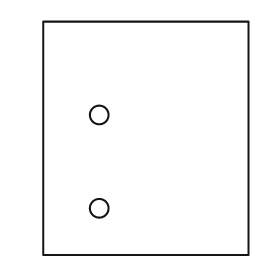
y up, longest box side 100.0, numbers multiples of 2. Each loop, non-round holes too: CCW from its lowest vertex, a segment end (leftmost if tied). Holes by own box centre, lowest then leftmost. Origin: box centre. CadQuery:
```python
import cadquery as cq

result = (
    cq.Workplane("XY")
    .moveTo(-44.0, -50.0)
    .lineTo(44.0, -50.0)
    .lineTo(44.0, 50.0)
    .lineTo(-44.0, 50.0)
    .close()
    .moveTo(-20.0, -30.0)
    .circle(4.0)
    .moveTo(-20.0, 10.0)
    .circle(4.0)
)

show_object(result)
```